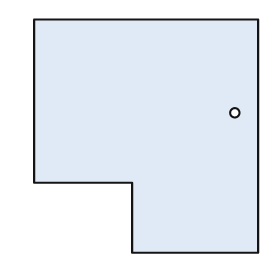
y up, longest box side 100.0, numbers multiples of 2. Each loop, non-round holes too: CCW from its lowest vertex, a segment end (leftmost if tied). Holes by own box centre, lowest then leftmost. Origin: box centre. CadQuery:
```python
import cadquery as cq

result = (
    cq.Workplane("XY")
    .moveTo(-6.0, -50.0)
    .lineTo(48.0, -50.0)
    .lineTo(48.0, 50.0)
    .lineTo(-48.0, 50.0)
    .lineTo(-48.0, -20.0)
    .lineTo(-6.0, -20.0)
    .close()
    .moveTo(38.0, 10.0)
    .circle(2.0)
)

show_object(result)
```